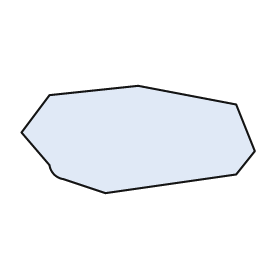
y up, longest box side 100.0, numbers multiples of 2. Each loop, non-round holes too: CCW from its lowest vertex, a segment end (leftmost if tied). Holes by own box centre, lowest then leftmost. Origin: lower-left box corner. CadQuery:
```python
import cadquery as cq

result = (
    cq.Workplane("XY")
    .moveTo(36.0, 0.0)
    .lineTo(92.0, 8.0)
    .lineTo(100.0, 18.0)
    .lineTo(92.0, 38.0)
    .lineTo(50.0, 46.0)
    .lineTo(12.0, 42.0)
    .lineTo(0.0, 26.0)
    .lineTo(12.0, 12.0)
    .threePointArc((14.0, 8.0), (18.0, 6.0))
    .close()
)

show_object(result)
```